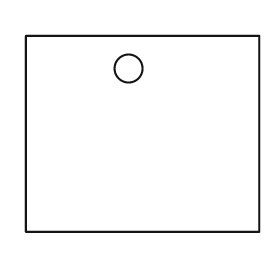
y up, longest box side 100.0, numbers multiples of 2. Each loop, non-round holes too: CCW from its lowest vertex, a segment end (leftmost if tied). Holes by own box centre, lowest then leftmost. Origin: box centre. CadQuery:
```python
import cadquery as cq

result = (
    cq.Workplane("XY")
    .moveTo(-50.0, -42.0)
    .lineTo(50.0, -42.0)
    .lineTo(50.0, 42.0)
    .lineTo(-50.0, 42.0)
    .close()
    .moveTo(-6.0, 28.0)
    .circle(6.0)
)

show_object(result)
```